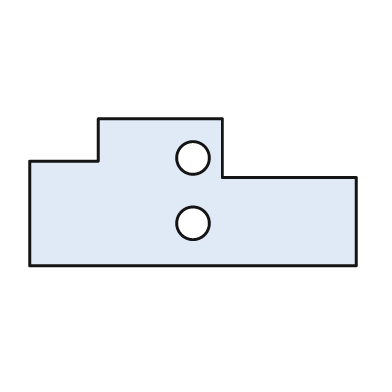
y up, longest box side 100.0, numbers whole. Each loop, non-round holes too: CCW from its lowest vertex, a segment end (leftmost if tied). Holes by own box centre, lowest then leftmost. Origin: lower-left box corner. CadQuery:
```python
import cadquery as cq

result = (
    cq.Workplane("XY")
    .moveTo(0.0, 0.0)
    .lineTo(100.0, 0.0)
    .lineTo(100.0, 27.0)
    .lineTo(59.0, 27.0)
    .lineTo(59.0, 45.0)
    .lineTo(21.0, 45.0)
    .lineTo(21.0, 32.0)
    .lineTo(0.0, 32.0)
    .close()
    .moveTo(50.0, 13.0)
    .circle(5.0)
    .moveTo(50.0, 33.0)
    .circle(5.0)
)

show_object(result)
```